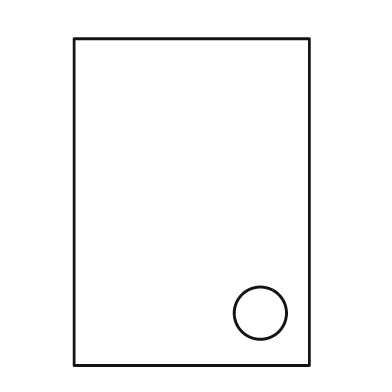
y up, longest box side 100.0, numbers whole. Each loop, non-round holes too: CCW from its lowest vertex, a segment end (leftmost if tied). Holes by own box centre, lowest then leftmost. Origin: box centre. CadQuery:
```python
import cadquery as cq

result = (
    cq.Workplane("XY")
    .moveTo(-36.0, -50.0)
    .lineTo(36.0, -50.0)
    .lineTo(36.0, 50.0)
    .lineTo(-36.0, 50.0)
    .close()
    .moveTo(21.0, -34.0)
    .circle(8.0)
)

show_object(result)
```